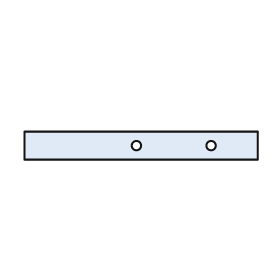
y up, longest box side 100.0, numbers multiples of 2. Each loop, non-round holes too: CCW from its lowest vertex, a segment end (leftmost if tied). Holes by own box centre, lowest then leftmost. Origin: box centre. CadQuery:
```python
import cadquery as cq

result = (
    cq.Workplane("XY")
    .moveTo(-50.0, -6.0)
    .lineTo(50.0, -6.0)
    .lineTo(50.0, 6.0)
    .lineTo(-50.0, 6.0)
    .close()
    .moveTo(-2.0, 0.0)
    .circle(2.0)
    .moveTo(30.0, 0.0)
    .circle(2.0)
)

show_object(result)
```